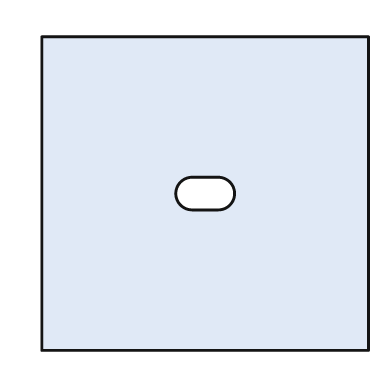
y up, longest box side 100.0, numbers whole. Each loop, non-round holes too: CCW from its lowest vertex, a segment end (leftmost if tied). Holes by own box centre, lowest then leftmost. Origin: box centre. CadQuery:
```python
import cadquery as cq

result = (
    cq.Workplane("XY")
    .moveTo(-50.0, -48.0)
    .lineTo(50.0, -48.0)
    .lineTo(50.0, 48.0)
    .lineTo(-50.0, 48.0)
    .close()
    .moveTo(-4.0, -5.0)
    .lineTo(4.0, -5.0)
    .threePointArc((9.0, 0.0), (4.0, 5.0))
    .lineTo(-4.0, 5.0)
    .threePointArc((-9.0, 0.0), (-4.0, -5.0))
    .close()
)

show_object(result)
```